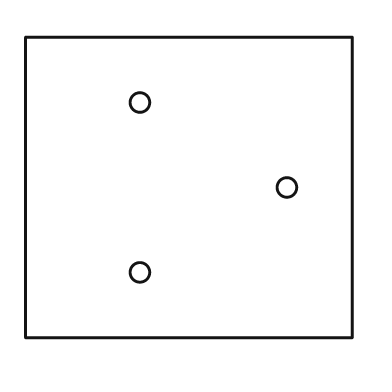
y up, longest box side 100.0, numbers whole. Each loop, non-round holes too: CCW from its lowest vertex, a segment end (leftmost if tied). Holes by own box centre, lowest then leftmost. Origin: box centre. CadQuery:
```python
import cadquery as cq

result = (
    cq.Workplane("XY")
    .moveTo(-50.0, -46.0)
    .lineTo(50.0, -46.0)
    .lineTo(50.0, 46.0)
    .lineTo(-50.0, 46.0)
    .close()
    .moveTo(-15.0, -26.0)
    .circle(3.0)
    .moveTo(30.0, 0.0)
    .circle(3.0)
    .moveTo(-15.0, 26.0)
    .circle(3.0)
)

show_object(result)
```